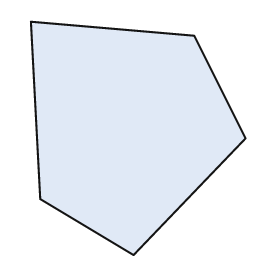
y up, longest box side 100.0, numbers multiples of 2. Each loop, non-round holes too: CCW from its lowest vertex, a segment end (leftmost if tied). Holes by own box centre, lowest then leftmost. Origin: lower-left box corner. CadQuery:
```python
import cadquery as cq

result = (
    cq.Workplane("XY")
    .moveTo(44.0, 0.0)
    .lineTo(92.0, 50.0)
    .lineTo(70.0, 94.0)
    .lineTo(0.0, 100.0)
    .lineTo(4.0, 24.0)
    .close()
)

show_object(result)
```